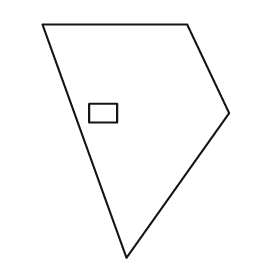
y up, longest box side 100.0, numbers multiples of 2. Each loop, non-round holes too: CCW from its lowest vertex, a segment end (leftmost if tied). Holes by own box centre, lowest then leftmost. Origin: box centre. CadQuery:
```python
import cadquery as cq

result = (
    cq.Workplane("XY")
    .moveTo(-4.0, -50.0)
    .lineTo(40.0, 12.0)
    .lineTo(22.0, 50.0)
    .lineTo(-40.0, 50.0)
    .close()
    .moveTo(-20.0, 8.0)
    .lineTo(-8.0, 8.0)
    .lineTo(-8.0, 16.0)
    .lineTo(-20.0, 16.0)
    .close()
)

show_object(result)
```